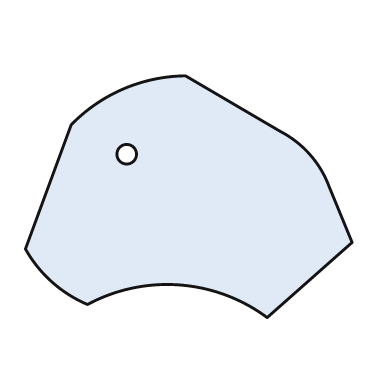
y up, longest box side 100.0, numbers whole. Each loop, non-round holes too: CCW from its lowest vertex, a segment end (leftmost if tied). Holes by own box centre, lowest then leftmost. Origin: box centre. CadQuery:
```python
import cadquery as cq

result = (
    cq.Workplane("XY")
    .moveTo(24.0, -37.0)
    .lineTo(50.0, -14.0)
    .lineTo(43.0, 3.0)
    .threePointArc((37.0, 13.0), (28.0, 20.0))
    .lineTo(-1.0, 37.0)
    .threePointArc((-20.0, 33.0), (-36.0, 22.0))
    .lineTo(-50.0, -16.0)
    .threePointArc((-42.0, -26.0), (-31.0, -33.0))
    .threePointArc((-3.0, -27.0), (24.0, -37.0))
    .close()
    .moveTo(-19.0, 13.0)
    .circle(3.0)
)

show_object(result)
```